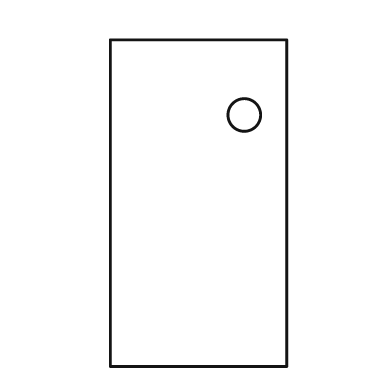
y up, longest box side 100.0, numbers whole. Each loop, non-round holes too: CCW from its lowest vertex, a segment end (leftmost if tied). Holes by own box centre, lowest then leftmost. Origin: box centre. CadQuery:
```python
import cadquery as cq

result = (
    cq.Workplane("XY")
    .moveTo(-27.0, -50.0)
    .lineTo(27.0, -50.0)
    .lineTo(27.0, 50.0)
    .lineTo(-27.0, 50.0)
    .close()
    .moveTo(14.0, 27.0)
    .circle(5.0)
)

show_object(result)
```